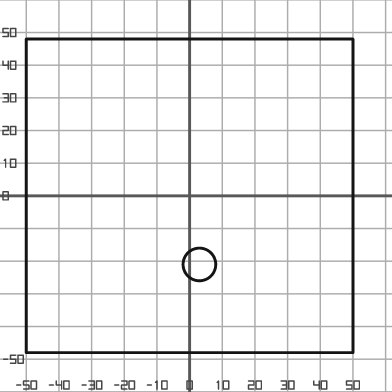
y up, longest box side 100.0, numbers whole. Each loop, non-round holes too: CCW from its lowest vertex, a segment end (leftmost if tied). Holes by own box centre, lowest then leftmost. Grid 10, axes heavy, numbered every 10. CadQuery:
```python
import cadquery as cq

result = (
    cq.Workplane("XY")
    .moveTo(-50.0, -48.0)
    .lineTo(50.0, -48.0)
    .lineTo(50.0, 48.0)
    .lineTo(-50.0, 48.0)
    .close()
    .moveTo(3.0, -21.0)
    .circle(5.0)
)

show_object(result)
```